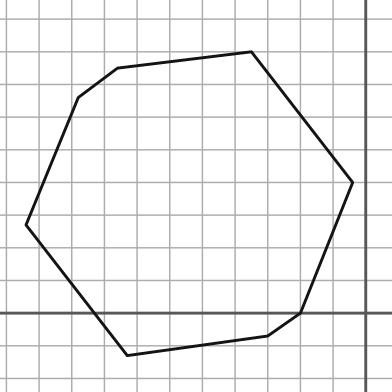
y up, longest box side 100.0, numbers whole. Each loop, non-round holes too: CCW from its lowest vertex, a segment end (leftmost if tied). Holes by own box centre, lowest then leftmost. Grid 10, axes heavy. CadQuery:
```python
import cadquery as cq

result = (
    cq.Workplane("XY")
    .moveTo(-73.0, -13.0)
    .lineTo(-30.0, -7.0)
    .lineTo(-20.0, 0.0)
    .lineTo(-4.0, 40.0)
    .lineTo(-35.0, 80.0)
    .lineTo(-76.0, 75.0)
    .lineTo(-88.0, 66.0)
    .lineTo(-104.0, 27.0)
    .close()
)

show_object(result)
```